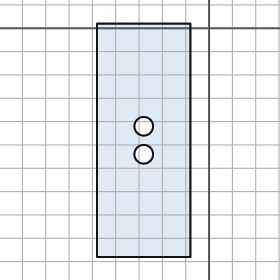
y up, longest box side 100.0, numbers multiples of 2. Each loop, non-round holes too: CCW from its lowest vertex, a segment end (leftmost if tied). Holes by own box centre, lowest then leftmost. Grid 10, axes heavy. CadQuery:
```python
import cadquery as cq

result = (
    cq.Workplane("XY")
    .moveTo(-48.0, -98.0)
    .lineTo(-8.0, -98.0)
    .lineTo(-8.0, 2.0)
    .lineTo(-48.0, 2.0)
    .close()
    .moveTo(-28.0, -54.0)
    .circle(4.0)
    .moveTo(-28.0, -42.0)
    .circle(4.0)
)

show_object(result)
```